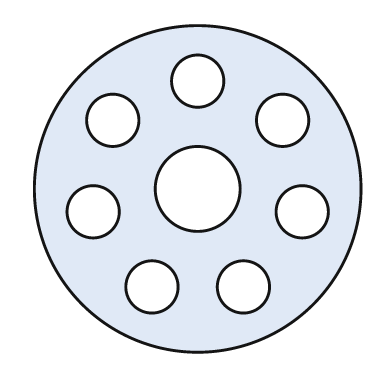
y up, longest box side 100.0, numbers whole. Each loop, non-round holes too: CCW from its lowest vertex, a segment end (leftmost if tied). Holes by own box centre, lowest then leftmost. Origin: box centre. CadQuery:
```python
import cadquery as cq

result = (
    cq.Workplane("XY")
    .moveTo(0.0, 0.0)
    .circle(50.0)
    .moveTo(-14.0, -30.0)
    .circle(8.0)
    .moveTo(14.0, -30.0)
    .circle(8.0)
    .moveTo(-32.0, -7.0)
    .circle(8.0)
    .moveTo(32.0, -7.0)
    .circle(8.0)
    .moveTo(0.0, 0.0)
    .circle(13.0)
    .moveTo(-26.0, 21.0)
    .circle(8.0)
    .moveTo(26.0, 21.0)
    .circle(8.0)
    .moveTo(0.0, 33.0)
    .circle(8.0)
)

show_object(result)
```